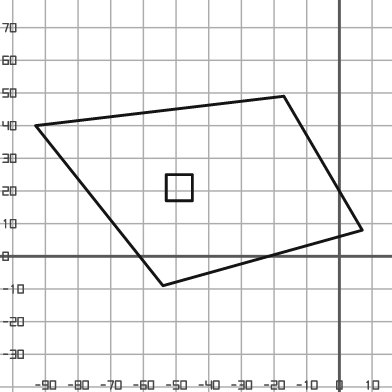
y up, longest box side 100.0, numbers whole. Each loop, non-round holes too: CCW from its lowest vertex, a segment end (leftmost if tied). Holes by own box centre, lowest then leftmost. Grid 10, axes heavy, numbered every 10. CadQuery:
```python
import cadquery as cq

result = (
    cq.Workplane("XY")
    .moveTo(-54.0, -9.0)
    .lineTo(7.0, 8.0)
    .lineTo(-17.0, 49.0)
    .lineTo(-93.0, 40.0)
    .close()
    .moveTo(-53.0, 17.0)
    .lineTo(-45.0, 17.0)
    .lineTo(-45.0, 25.0)
    .lineTo(-53.0, 25.0)
    .close()
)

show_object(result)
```